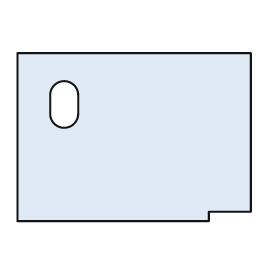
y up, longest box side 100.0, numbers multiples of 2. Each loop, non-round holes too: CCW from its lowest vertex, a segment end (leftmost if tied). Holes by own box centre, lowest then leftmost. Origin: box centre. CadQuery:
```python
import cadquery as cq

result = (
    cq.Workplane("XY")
    .moveTo(-50.0, -36.0)
    .lineTo(32.0, -36.0)
    .lineTo(32.0, -32.0)
    .lineTo(50.0, -32.0)
    .lineTo(50.0, 36.0)
    .lineTo(-50.0, 36.0)
    .close()
    .moveTo(-36.0, 10.0)
    .threePointArc((-30.0, 4.0), (-24.0, 10.0))
    .lineTo(-24.0, 18.0)
    .threePointArc((-30.0, 24.0), (-36.0, 18.0))
    .close()
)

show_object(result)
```